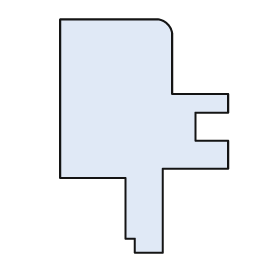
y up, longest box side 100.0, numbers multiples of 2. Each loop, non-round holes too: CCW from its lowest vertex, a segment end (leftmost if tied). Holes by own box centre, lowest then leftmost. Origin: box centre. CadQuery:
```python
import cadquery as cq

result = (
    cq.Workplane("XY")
    .moveTo(-4.0, -50.0)
    .lineTo(8.0, -50.0)
    .lineTo(8.0, -14.0)
    .lineTo(36.0, -14.0)
    .lineTo(36.0, -2.0)
    .lineTo(22.0, -2.0)
    .lineTo(22.0, 10.0)
    .lineTo(36.0, 10.0)
    .lineTo(36.0, 18.0)
    .lineTo(12.0, 18.0)
    .lineTo(12.0, 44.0)
    .threePointArc((10.0, 48.0), (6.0, 50.0))
    .lineTo(-36.0, 50.0)
    .lineTo(-36.0, -18.0)
    .lineTo(-8.0, -18.0)
    .lineTo(-8.0, -44.0)
    .lineTo(-4.0, -44.0)
    .close()
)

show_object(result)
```